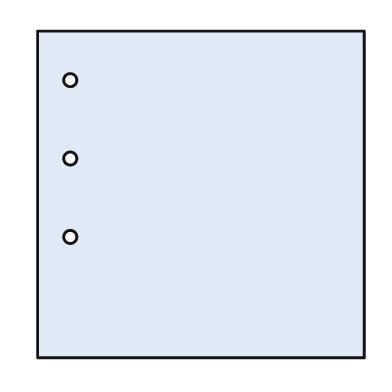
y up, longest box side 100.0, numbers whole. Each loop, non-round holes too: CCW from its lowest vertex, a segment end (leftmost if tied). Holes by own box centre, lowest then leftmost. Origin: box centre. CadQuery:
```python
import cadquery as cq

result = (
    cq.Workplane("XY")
    .moveTo(-50.0, -50.0)
    .lineTo(50.0, -50.0)
    .lineTo(50.0, 50.0)
    .lineTo(-50.0, 50.0)
    .close()
    .moveTo(-40.0, -13.0)
    .circle(2.0)
    .moveTo(-40.0, 11.0)
    .circle(2.0)
    .moveTo(-40.0, 35.0)
    .circle(2.0)
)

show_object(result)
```